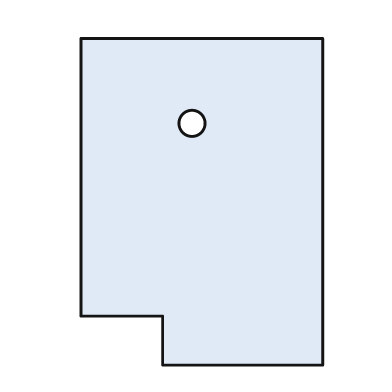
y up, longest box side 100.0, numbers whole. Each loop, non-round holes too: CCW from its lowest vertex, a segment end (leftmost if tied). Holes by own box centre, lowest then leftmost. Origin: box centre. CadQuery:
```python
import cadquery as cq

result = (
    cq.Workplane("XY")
    .moveTo(-12.0, -50.0)
    .lineTo(37.0, -50.0)
    .lineTo(37.0, 50.0)
    .lineTo(-37.0, 50.0)
    .lineTo(-37.0, -35.0)
    .lineTo(-12.0, -35.0)
    .close()
    .moveTo(-3.0, 24.0)
    .circle(4.0)
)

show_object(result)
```